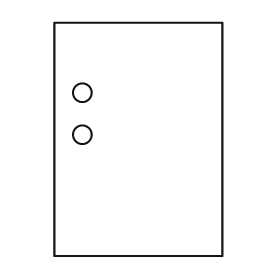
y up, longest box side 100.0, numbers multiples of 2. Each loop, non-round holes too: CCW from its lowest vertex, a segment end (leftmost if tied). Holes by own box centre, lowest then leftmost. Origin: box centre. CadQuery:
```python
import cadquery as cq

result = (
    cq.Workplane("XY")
    .moveTo(-36.0, -50.0)
    .lineTo(36.0, -50.0)
    .lineTo(36.0, 50.0)
    .lineTo(-36.0, 50.0)
    .close()
    .moveTo(-24.0, 2.0)
    .circle(4.0)
    .moveTo(-24.0, 20.0)
    .circle(4.0)
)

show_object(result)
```